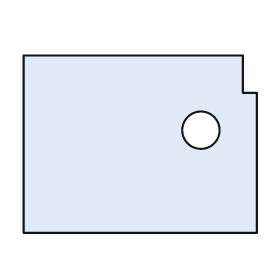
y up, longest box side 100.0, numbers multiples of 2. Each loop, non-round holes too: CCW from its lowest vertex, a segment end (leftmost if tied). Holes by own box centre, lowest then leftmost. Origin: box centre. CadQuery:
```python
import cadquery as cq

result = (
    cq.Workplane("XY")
    .moveTo(-50.0, -38.0)
    .lineTo(50.0, -38.0)
    .lineTo(50.0, 22.0)
    .lineTo(44.0, 22.0)
    .lineTo(44.0, 38.0)
    .lineTo(-50.0, 38.0)
    .close()
    .moveTo(26.0, 6.0)
    .circle(8.0)
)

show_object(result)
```